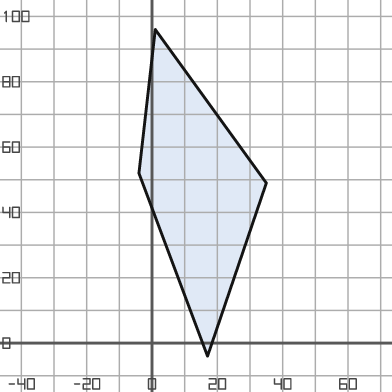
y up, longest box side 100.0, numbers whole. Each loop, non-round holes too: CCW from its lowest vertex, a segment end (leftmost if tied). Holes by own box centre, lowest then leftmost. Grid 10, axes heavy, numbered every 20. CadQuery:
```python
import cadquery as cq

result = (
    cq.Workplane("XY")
    .moveTo(17.0, -4.0)
    .lineTo(35.0, 49.0)
    .lineTo(1.0, 96.0)
    .lineTo(-4.0, 52.0)
    .close()
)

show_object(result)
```